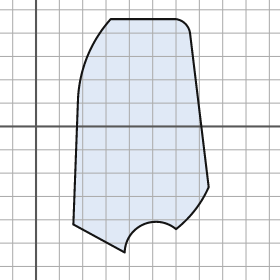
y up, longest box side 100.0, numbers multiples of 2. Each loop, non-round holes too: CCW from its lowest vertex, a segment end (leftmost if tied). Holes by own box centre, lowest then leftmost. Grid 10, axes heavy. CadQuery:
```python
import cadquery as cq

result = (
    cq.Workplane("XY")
    .moveTo(38.0, -54.0)
    .threePointArc((46.0, -42.0), (60.0, -44.0))
    .threePointArc((68.0, -36.0), (74.0, -26.0))
    .lineTo(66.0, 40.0)
    .threePointArc((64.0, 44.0), (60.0, 46.0))
    .lineTo(32.0, 46.0)
    .threePointArc((22.0, 30.0), (18.0, 12.0))
    .lineTo(16.0, -42.0)
    .close()
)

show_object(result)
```